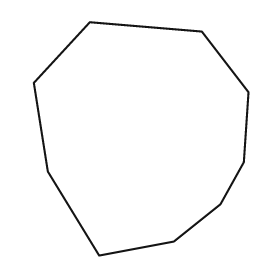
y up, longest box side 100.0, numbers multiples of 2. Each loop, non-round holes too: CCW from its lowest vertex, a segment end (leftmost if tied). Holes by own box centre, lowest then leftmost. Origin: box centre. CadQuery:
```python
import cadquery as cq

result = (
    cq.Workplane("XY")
    .moveTo(-18.0, -50.0)
    .lineTo(14.0, -44.0)
    .lineTo(34.0, -28.0)
    .lineTo(44.0, -10.0)
    .lineTo(46.0, 20.0)
    .lineTo(26.0, 46.0)
    .lineTo(-22.0, 50.0)
    .lineTo(-46.0, 24.0)
    .lineTo(-40.0, -14.0)
    .close()
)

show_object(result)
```